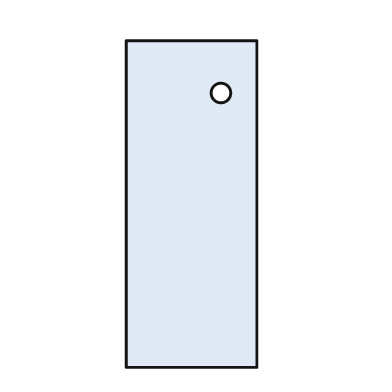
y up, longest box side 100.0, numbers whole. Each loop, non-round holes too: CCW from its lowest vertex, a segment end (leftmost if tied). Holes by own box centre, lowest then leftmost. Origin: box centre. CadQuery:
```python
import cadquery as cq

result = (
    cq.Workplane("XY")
    .moveTo(-20.0, -50.0)
    .lineTo(20.0, -50.0)
    .lineTo(20.0, 50.0)
    .lineTo(-20.0, 50.0)
    .close()
    .moveTo(9.0, 34.0)
    .circle(3.0)
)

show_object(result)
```